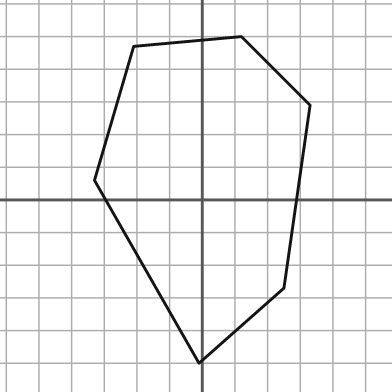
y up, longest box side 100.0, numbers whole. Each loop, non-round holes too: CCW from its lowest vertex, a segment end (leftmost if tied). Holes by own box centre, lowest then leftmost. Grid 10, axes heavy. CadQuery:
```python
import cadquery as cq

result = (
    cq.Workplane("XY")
    .moveTo(-1.0, -50.0)
    .lineTo(25.0, -27.0)
    .lineTo(33.0, 29.0)
    .lineTo(12.0, 50.0)
    .lineTo(-21.0, 47.0)
    .lineTo(-33.0, 6.0)
    .close()
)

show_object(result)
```